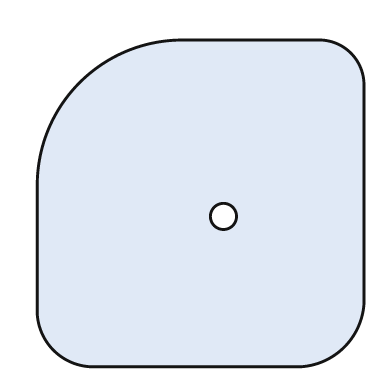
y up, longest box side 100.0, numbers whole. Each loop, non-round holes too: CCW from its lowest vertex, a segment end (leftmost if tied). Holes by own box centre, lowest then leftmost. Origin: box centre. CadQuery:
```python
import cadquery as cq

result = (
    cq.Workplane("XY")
    .moveTo(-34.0, -50.0)
    .lineTo(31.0, -50.0)
    .threePointArc((44.0, -44.0), (50.0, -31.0))
    .lineTo(50.0, 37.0)
    .threePointArc((46.0, 46.0), (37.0, 50.0))
    .lineTo(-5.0, 50.0)
    .threePointArc((-37.0, 37.0), (-50.0, 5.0))
    .lineTo(-50.0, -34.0)
    .threePointArc((-45.0, -45.0), (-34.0, -50.0))
    .close()
    .moveTo(7.0, -4.0)
    .circle(4.0)
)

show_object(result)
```